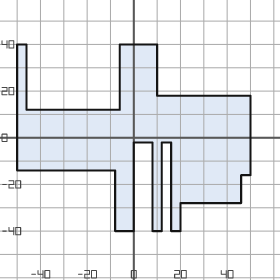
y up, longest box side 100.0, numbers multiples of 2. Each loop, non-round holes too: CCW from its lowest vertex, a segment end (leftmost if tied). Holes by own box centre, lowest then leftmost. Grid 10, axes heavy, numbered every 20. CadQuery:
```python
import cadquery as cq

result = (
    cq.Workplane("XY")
    .moveTo(-8.0, -40.0)
    .lineTo(0.0, -40.0)
    .lineTo(0.0, -2.0)
    .lineTo(8.0, -2.0)
    .lineTo(8.0, -40.0)
    .lineTo(12.0, -40.0)
    .lineTo(12.0, -2.0)
    .lineTo(16.0, -2.0)
    .lineTo(16.0, -40.0)
    .lineTo(20.0, -40.0)
    .lineTo(20.0, -28.0)
    .lineTo(46.0, -28.0)
    .lineTo(46.0, -16.0)
    .lineTo(50.0, -16.0)
    .lineTo(50.0, 18.0)
    .lineTo(10.0, 18.0)
    .lineTo(10.0, 40.0)
    .lineTo(-6.0, 40.0)
    .lineTo(-6.0, 12.0)
    .lineTo(-46.0, 12.0)
    .lineTo(-46.0, 40.0)
    .lineTo(-50.0, 40.0)
    .lineTo(-50.0, -14.0)
    .lineTo(-8.0, -14.0)
    .close()
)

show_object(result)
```